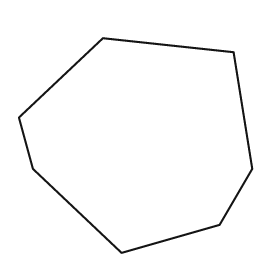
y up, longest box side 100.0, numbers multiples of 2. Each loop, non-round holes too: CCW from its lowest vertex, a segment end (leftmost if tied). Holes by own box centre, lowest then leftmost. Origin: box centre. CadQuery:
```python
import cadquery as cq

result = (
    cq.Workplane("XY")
    .moveTo(-6.0, -46.0)
    .lineTo(36.0, -34.0)
    .lineTo(50.0, -10.0)
    .lineTo(42.0, 40.0)
    .lineTo(-14.0, 46.0)
    .lineTo(-50.0, 12.0)
    .lineTo(-44.0, -10.0)
    .close()
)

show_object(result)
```